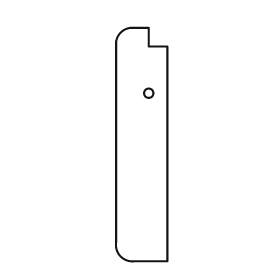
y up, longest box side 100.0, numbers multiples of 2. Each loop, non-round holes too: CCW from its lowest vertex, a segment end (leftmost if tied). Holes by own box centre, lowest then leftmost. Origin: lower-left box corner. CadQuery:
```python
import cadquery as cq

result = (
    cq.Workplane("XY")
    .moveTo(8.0, 0.0)
    .lineTo(22.0, 0.0)
    .lineTo(22.0, 92.0)
    .lineTo(14.0, 92.0)
    .lineTo(14.0, 100.0)
    .lineTo(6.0, 100.0)
    .threePointArc((2.0, 98.0), (0.0, 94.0))
    .lineTo(0.0, 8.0)
    .threePointArc((2.0, 2.0), (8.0, 0.0))
    .close()
    .moveTo(14.0, 72.0)
    .circle(2.0)
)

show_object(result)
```